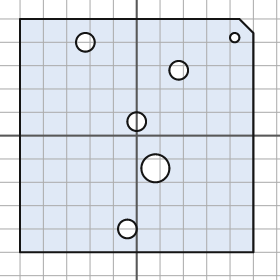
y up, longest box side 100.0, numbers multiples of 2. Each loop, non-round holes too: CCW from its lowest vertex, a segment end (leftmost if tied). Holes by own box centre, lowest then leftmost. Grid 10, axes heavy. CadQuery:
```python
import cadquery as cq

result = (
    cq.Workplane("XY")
    .moveTo(-50.0, -50.0)
    .lineTo(50.0, -50.0)
    .lineTo(50.0, 44.0)
    .lineTo(44.0, 50.0)
    .lineTo(-50.0, 50.0)
    .close()
    .moveTo(-4.0, -40.0)
    .circle(4.0)
    .moveTo(8.0, -14.0)
    .circle(6.0)
    .moveTo(0.0, 6.0)
    .circle(4.0)
    .moveTo(18.0, 28.0)
    .circle(4.0)
    .moveTo(-22.0, 40.0)
    .circle(4.0)
    .moveTo(42.0, 42.0)
    .circle(2.0)
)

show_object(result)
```